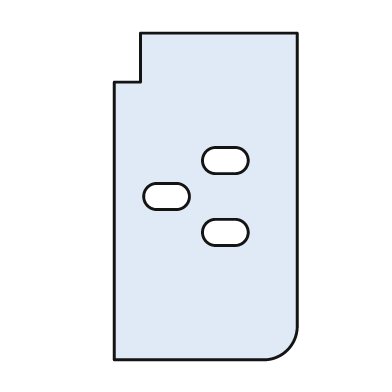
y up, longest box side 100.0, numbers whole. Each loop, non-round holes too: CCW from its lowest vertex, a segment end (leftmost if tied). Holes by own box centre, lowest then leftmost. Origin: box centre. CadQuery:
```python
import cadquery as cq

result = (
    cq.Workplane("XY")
    .moveTo(-28.0, -50.0)
    .lineTo(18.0, -50.0)
    .threePointArc((25.0, -47.0), (28.0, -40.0))
    .lineTo(28.0, 50.0)
    .lineTo(-20.0, 50.0)
    .lineTo(-20.0, 35.0)
    .lineTo(-28.0, 35.0)
    .close()
    .moveTo(3.0, -15.0)
    .lineTo(9.0, -15.0)
    .threePointArc((13.0, -11.0), (9.0, -7.0))
    .lineTo(3.0, -7.0)
    .threePointArc((-1.0, -11.0), (3.0, -15.0))
    .close()
    .moveTo(-15.0, -4.0)
    .lineTo(-9.0, -4.0)
    .threePointArc((-5.0, 0.0), (-9.0, 4.0))
    .lineTo(-15.0, 4.0)
    .threePointArc((-19.0, 0.0), (-15.0, -4.0))
    .close()
    .moveTo(3.0, 7.0)
    .lineTo(9.0, 7.0)
    .threePointArc((13.0, 11.0), (9.0, 15.0))
    .lineTo(3.0, 15.0)
    .threePointArc((-1.0, 11.0), (3.0, 7.0))
    .close()
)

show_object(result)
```